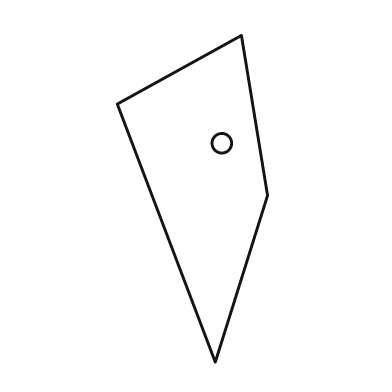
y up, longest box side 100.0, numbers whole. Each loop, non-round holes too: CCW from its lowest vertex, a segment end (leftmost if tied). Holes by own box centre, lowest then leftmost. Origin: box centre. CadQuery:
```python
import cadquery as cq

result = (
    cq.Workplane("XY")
    .moveTo(7.0, -50.0)
    .lineTo(23.0, 1.0)
    .lineTo(15.0, 50.0)
    .lineTo(-23.0, 29.0)
    .close()
    .moveTo(9.0, 17.0)
    .circle(3.0)
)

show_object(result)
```